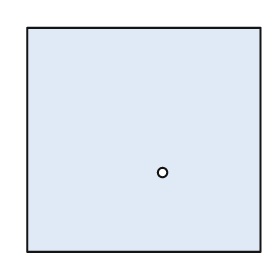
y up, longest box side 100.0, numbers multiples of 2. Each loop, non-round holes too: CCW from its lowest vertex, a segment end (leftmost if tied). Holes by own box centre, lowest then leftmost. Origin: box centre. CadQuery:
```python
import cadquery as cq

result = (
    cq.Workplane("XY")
    .moveTo(-50.0, -48.0)
    .lineTo(50.0, -48.0)
    .lineTo(50.0, 48.0)
    .lineTo(-50.0, 48.0)
    .close()
    .moveTo(8.0, -14.0)
    .circle(2.0)
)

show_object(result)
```